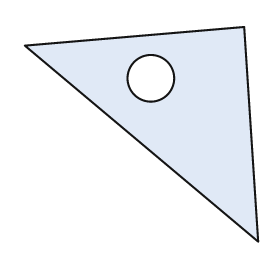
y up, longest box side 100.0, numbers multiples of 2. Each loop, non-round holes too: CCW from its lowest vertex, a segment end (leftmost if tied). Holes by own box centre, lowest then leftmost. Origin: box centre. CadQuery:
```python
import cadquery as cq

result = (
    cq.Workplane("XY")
    .moveTo(50.0, -46.0)
    .lineTo(44.0, 46.0)
    .lineTo(-50.0, 38.0)
    .close()
    .moveTo(4.0, 24.0)
    .circle(10.0)
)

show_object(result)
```